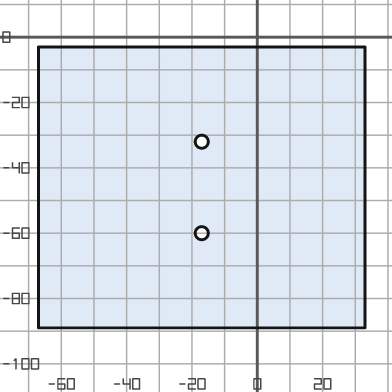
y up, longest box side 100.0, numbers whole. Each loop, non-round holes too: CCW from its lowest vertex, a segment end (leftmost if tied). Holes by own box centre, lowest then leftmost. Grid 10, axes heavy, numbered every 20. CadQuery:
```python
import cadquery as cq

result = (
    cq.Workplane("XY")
    .moveTo(-67.0, -89.0)
    .lineTo(33.0, -89.0)
    .lineTo(33.0, -3.0)
    .lineTo(-67.0, -3.0)
    .close()
    .moveTo(-17.0, -60.0)
    .circle(2.0)
    .moveTo(-17.0, -32.0)
    .circle(2.0)
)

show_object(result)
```